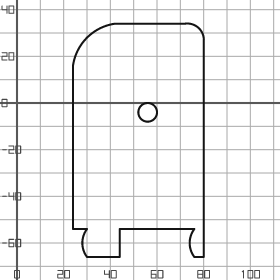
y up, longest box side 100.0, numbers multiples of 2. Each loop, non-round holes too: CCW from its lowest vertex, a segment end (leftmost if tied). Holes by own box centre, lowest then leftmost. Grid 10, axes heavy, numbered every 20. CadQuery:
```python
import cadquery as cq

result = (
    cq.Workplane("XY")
    .moveTo(30.0, -66.0)
    .lineTo(44.0, -66.0)
    .lineTo(44.0, -54.0)
    .lineTo(76.0, -54.0)
    .threePointArc((74.0, -60.0), (76.0, -66.0))
    .lineTo(80.0, -66.0)
    .lineTo(80.0, 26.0)
    .threePointArc((78.0, 32.0), (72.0, 34.0))
    .lineTo(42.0, 34.0)
    .threePointArc((30.0, 28.0), (24.0, 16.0))
    .lineTo(24.0, -54.0)
    .lineTo(30.0, -54.0)
    .threePointArc((28.0, -60.0), (30.0, -66.0))
    .close()
    .moveTo(56.0, -4.0)
    .circle(4.0)
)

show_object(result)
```